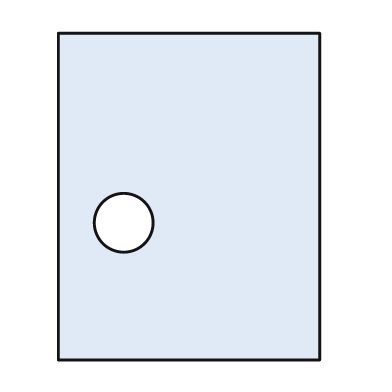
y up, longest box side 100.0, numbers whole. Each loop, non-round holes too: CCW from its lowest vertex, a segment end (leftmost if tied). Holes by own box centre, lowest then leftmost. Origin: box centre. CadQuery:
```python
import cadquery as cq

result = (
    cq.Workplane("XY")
    .moveTo(-40.0, -50.0)
    .lineTo(40.0, -50.0)
    .lineTo(40.0, 50.0)
    .lineTo(-40.0, 50.0)
    .close()
    .moveTo(-20.0, -8.0)
    .circle(9.0)
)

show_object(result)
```